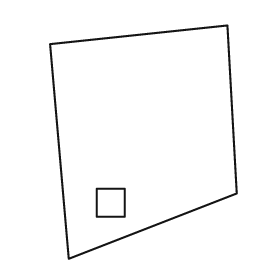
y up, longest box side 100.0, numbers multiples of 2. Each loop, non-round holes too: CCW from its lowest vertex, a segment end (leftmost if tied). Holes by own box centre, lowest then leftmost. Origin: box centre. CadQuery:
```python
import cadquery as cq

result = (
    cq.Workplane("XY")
    .moveTo(-32.0, -50.0)
    .lineTo(40.0, -22.0)
    .lineTo(36.0, 50.0)
    .lineTo(-40.0, 42.0)
    .close()
    .moveTo(-20.0, -32.0)
    .lineTo(-8.0, -32.0)
    .lineTo(-8.0, -20.0)
    .lineTo(-20.0, -20.0)
    .close()
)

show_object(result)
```